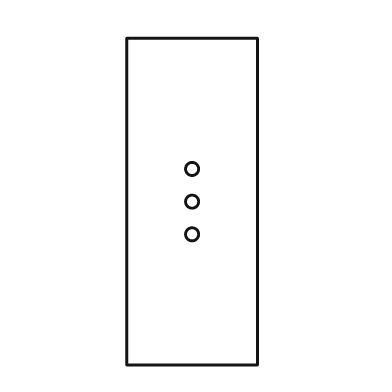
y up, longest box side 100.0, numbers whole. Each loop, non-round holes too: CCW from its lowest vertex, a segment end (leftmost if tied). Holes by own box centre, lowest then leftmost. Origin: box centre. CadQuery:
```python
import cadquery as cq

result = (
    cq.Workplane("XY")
    .moveTo(-20.0, -50.0)
    .lineTo(20.0, -50.0)
    .lineTo(20.0, 50.0)
    .lineTo(-20.0, 50.0)
    .close()
    .moveTo(0.0, -10.0)
    .circle(2.0)
    .moveTo(0.0, 0.0)
    .circle(2.0)
    .moveTo(0.0, 10.0)
    .circle(2.0)
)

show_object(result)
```